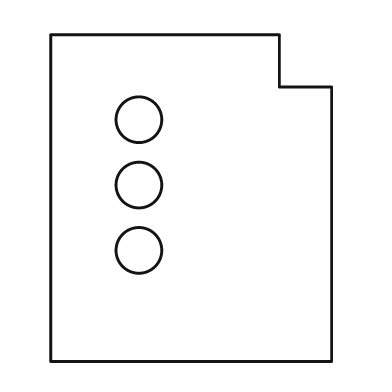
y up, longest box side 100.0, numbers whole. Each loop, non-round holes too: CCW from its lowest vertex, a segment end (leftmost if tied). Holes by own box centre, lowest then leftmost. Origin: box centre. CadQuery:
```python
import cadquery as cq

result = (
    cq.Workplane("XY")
    .moveTo(-43.0, -50.0)
    .lineTo(43.0, -50.0)
    .lineTo(43.0, 34.0)
    .lineTo(27.0, 34.0)
    .lineTo(27.0, 50.0)
    .lineTo(-43.0, 50.0)
    .close()
    .moveTo(-16.0, -16.0)
    .circle(7.0)
    .moveTo(-16.0, 4.0)
    .circle(7.0)
    .moveTo(-16.0, 24.0)
    .circle(7.0)
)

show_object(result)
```